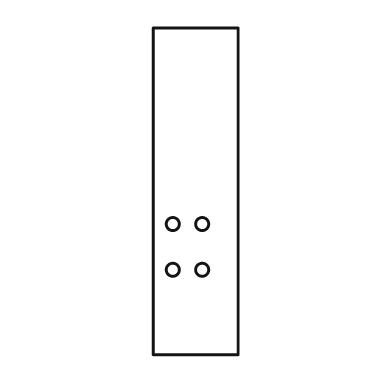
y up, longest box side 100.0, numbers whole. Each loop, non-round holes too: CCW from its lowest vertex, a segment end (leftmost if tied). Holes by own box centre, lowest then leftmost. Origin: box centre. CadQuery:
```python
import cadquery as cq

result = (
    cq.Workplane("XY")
    .moveTo(-13.0, -50.0)
    .lineTo(13.0, -50.0)
    .lineTo(13.0, 50.0)
    .lineTo(-13.0, 50.0)
    .close()
    .moveTo(-7.0, -24.0)
    .circle(2.0)
    .moveTo(2.0, -24.0)
    .circle(2.0)
    .moveTo(-7.0, -10.0)
    .circle(2.0)
    .moveTo(2.0, -10.0)
    .circle(2.0)
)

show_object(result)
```